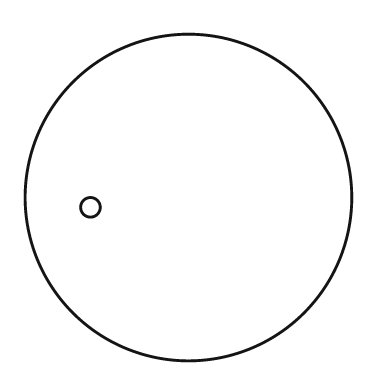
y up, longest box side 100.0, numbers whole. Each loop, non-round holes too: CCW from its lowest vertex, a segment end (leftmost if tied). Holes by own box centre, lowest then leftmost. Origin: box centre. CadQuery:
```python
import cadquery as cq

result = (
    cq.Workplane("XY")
    .moveTo(0.0, 0.0)
    .circle(50.0)
    .moveTo(-30.0, -3.0)
    .circle(3.0)
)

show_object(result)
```